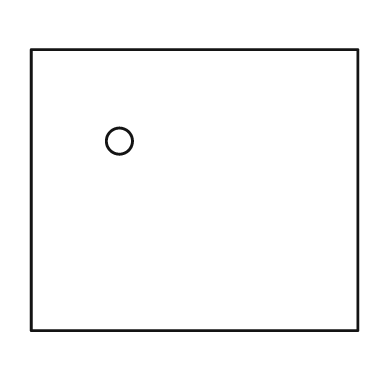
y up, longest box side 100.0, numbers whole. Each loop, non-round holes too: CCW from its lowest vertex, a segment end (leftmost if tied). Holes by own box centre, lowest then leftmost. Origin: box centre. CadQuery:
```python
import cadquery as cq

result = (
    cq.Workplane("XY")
    .moveTo(-50.0, -43.0)
    .lineTo(50.0, -43.0)
    .lineTo(50.0, 43.0)
    .lineTo(-50.0, 43.0)
    .close()
    .moveTo(-23.0, 15.0)
    .circle(4.0)
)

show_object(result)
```